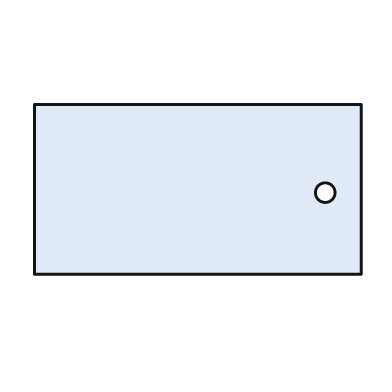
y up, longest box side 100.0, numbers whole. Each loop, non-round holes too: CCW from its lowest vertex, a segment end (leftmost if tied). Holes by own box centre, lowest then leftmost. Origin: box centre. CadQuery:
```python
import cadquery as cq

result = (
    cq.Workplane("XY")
    .moveTo(-50.0, -26.0)
    .lineTo(50.0, -26.0)
    .lineTo(50.0, 26.0)
    .lineTo(-50.0, 26.0)
    .close()
    .moveTo(39.0, -1.0)
    .circle(3.0)
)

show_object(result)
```